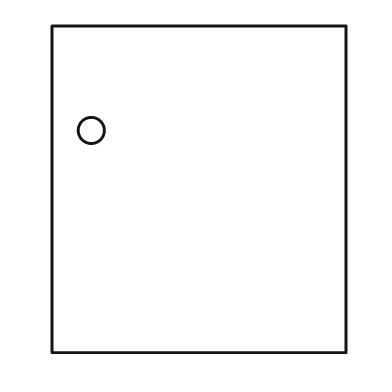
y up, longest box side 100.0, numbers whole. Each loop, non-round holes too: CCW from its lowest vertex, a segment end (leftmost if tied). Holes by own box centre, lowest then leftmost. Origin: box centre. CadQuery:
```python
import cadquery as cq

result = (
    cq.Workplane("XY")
    .moveTo(-45.0, -50.0)
    .lineTo(45.0, -50.0)
    .lineTo(45.0, 50.0)
    .lineTo(-45.0, 50.0)
    .close()
    .moveTo(-33.0, 18.0)
    .circle(4.0)
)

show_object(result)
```